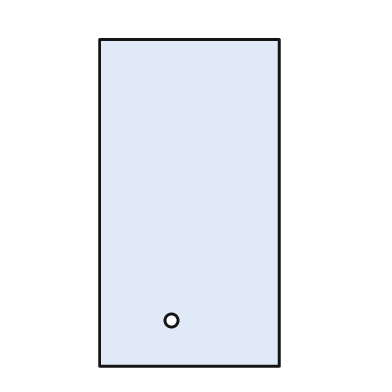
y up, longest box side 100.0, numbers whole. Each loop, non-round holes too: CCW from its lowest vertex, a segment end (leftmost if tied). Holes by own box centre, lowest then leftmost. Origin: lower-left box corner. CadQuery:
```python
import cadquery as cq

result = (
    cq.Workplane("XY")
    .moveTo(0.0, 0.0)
    .lineTo(55.0, 0.0)
    .lineTo(55.0, 100.0)
    .lineTo(0.0, 100.0)
    .close()
    .moveTo(22.0, 14.0)
    .circle(2.0)
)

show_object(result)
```